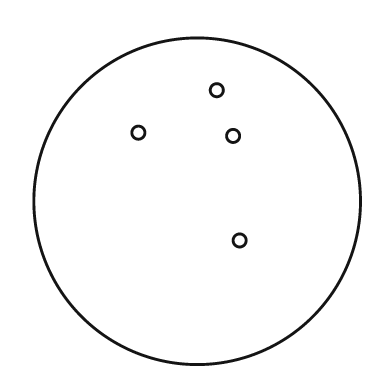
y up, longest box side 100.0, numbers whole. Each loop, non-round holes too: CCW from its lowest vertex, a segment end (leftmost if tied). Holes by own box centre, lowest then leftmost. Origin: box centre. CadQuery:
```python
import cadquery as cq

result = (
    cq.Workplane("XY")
    .moveTo(0.0, 0.0)
    .circle(50.0)
    .moveTo(13.0, -12.0)
    .circle(2.0)
    .moveTo(11.0, 20.0)
    .circle(2.0)
    .moveTo(-18.0, 21.0)
    .circle(2.0)
    .moveTo(6.0, 34.0)
    .circle(2.0)
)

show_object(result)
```